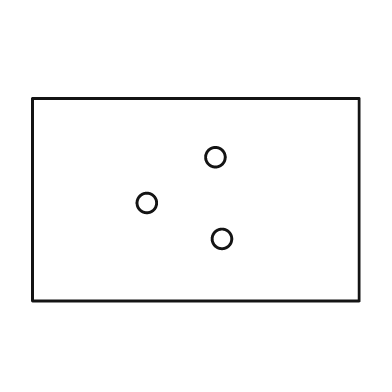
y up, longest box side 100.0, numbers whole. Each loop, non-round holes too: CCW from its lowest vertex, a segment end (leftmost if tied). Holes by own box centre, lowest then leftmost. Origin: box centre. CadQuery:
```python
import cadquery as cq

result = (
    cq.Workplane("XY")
    .moveTo(-50.0, -31.0)
    .lineTo(50.0, -31.0)
    .lineTo(50.0, 31.0)
    .lineTo(-50.0, 31.0)
    .close()
    .moveTo(8.0, -12.0)
    .circle(3.0)
    .moveTo(-15.0, -1.0)
    .circle(3.0)
    .moveTo(6.0, 13.0)
    .circle(3.0)
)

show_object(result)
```